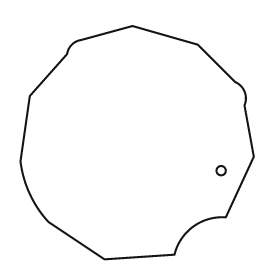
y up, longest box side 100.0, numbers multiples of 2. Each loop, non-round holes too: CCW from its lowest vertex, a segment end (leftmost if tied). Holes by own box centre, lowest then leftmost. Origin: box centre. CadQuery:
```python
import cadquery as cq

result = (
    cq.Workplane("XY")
    .moveTo(-14.0, -50.0)
    .lineTo(16.0, -48.0)
    .threePointArc((24.0, -36.0), (38.0, -32.0))
    .lineTo(50.0, -6.0)
    .lineTo(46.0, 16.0)
    .threePointArc((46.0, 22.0), (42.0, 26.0))
    .lineTo(26.0, 42.0)
    .lineTo(-2.0, 50.0)
    .lineTo(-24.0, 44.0)
    .threePointArc((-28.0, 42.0), (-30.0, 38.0))
    .lineTo(-46.0, 20.0)
    .lineTo(-50.0, -8.0)
    .threePointArc((-46.0, -22.0), (-38.0, -34.0))
    .close()
    .moveTo(36.0, -12.0)
    .circle(2.0)
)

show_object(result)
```